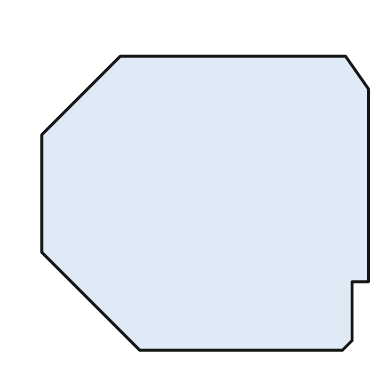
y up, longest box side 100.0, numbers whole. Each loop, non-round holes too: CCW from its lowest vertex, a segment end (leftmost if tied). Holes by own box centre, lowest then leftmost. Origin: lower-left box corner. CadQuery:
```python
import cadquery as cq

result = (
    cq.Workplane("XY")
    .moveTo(30.0, 0.0)
    .lineTo(92.0, 0.0)
    .lineTo(95.0, 3.0)
    .lineTo(95.0, 21.0)
    .lineTo(100.0, 21.0)
    .lineTo(100.0, 80.0)
    .lineTo(93.0, 90.0)
    .lineTo(24.0, 90.0)
    .lineTo(0.0, 66.0)
    .lineTo(0.0, 30.0)
    .close()
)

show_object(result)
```